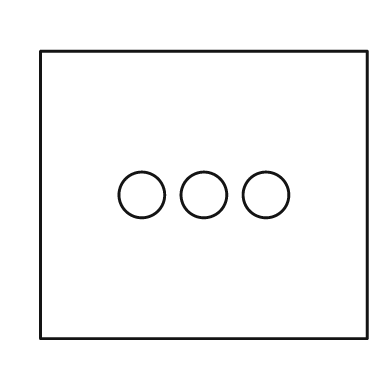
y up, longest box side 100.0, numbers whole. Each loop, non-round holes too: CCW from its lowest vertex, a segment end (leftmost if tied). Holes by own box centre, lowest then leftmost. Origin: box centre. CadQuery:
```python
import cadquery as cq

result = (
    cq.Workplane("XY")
    .moveTo(-50.0, -44.0)
    .lineTo(50.0, -44.0)
    .lineTo(50.0, 44.0)
    .lineTo(-50.0, 44.0)
    .close()
    .moveTo(-19.0, 0.0)
    .circle(7.0)
    .moveTo(0.0, 0.0)
    .circle(7.0)
    .moveTo(19.0, 0.0)
    .circle(7.0)
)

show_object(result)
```